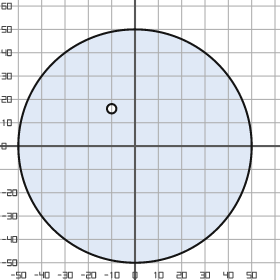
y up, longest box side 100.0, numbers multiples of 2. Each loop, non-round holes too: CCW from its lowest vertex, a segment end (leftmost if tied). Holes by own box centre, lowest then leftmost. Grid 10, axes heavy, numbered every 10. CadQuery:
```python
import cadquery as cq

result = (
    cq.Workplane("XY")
    .moveTo(0.0, 0.0)
    .circle(50.0)
    .moveTo(-10.0, 16.0)
    .circle(2.0)
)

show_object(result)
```